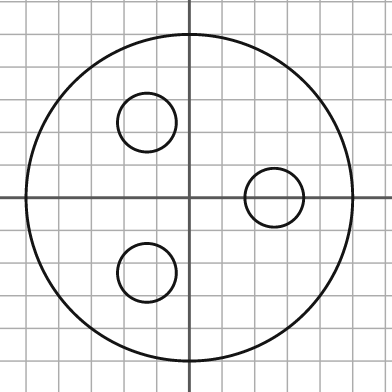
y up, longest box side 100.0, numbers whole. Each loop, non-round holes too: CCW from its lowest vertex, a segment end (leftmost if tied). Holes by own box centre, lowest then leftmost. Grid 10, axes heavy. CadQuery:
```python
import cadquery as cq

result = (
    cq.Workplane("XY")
    .moveTo(0.0, 0.0)
    .circle(50.0)
    .moveTo(-13.0, -23.0)
    .circle(9.0)
    .moveTo(26.0, 0.0)
    .circle(9.0)
    .moveTo(-13.0, 23.0)
    .circle(9.0)
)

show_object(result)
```